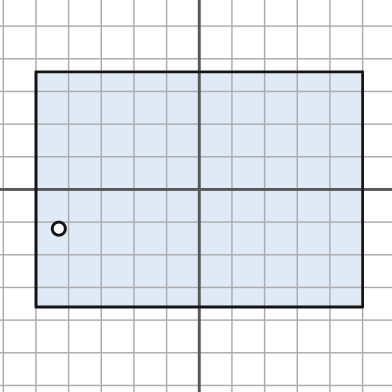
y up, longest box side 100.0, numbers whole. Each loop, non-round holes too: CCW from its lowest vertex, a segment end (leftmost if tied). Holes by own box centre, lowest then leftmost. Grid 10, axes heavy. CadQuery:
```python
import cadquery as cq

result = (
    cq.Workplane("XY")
    .moveTo(-50.0, -36.0)
    .lineTo(50.0, -36.0)
    .lineTo(50.0, 36.0)
    .lineTo(-50.0, 36.0)
    .close()
    .moveTo(-43.0, -12.0)
    .circle(2.0)
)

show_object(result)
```